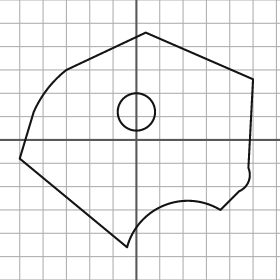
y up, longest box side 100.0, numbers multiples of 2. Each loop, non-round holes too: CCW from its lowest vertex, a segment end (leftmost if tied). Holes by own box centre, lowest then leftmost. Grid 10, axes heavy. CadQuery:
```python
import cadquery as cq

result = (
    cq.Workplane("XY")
    .moveTo(-4.0, -46.0)
    .threePointArc((12.0, -28.0), (36.0, -30.0))
    .lineTo(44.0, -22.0)
    .threePointArc((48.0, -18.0), (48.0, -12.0))
    .lineTo(50.0, 26.0)
    .lineTo(4.0, 46.0)
    .lineTo(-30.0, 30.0)
    .threePointArc((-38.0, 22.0), (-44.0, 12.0))
    .lineTo(-50.0, -8.0)
    .close()
    .moveTo(0.0, 12.0)
    .circle(8.0)
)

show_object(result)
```